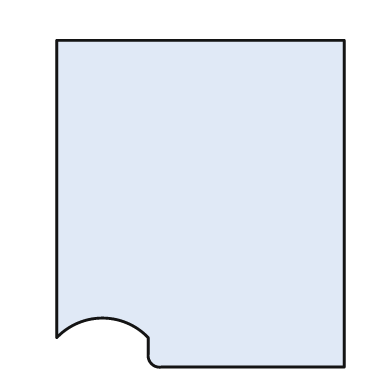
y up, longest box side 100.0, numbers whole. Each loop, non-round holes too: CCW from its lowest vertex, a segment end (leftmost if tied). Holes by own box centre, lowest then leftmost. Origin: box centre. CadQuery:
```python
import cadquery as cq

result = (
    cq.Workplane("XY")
    .moveTo(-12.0, -50.0)
    .lineTo(44.0, -50.0)
    .lineTo(44.0, 50.0)
    .lineTo(-44.0, 50.0)
    .lineTo(-44.0, -41.0)
    .threePointArc((-30.0, -35.0), (-16.0, -41.0))
    .lineTo(-16.0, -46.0)
    .threePointArc((-15.0, -49.0), (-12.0, -50.0))
    .close()
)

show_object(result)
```